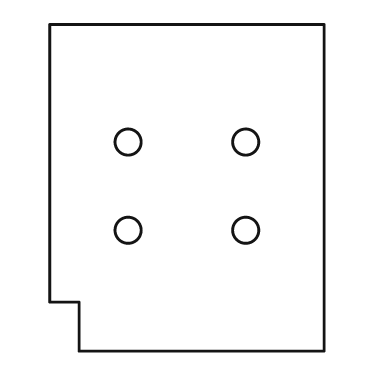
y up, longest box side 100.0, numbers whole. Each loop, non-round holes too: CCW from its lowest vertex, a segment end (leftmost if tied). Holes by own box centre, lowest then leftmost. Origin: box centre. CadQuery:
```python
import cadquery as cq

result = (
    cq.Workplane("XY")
    .moveTo(-33.0, -50.0)
    .lineTo(42.0, -50.0)
    .lineTo(42.0, 50.0)
    .lineTo(-42.0, 50.0)
    .lineTo(-42.0, -35.0)
    .lineTo(-33.0, -35.0)
    .close()
    .moveTo(-18.0, -13.0)
    .circle(4.0)
    .moveTo(18.0, -13.0)
    .circle(4.0)
    .moveTo(-18.0, 14.0)
    .circle(4.0)
    .moveTo(18.0, 14.0)
    .circle(4.0)
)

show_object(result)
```